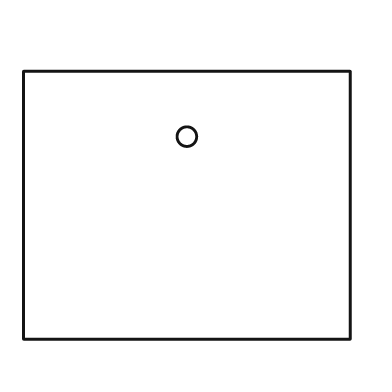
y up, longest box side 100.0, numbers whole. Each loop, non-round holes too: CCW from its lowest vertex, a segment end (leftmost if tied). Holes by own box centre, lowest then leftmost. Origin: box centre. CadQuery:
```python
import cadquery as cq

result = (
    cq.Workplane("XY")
    .moveTo(-50.0, -41.0)
    .lineTo(50.0, -41.0)
    .lineTo(50.0, 41.0)
    .lineTo(-50.0, 41.0)
    .close()
    .moveTo(0.0, 21.0)
    .circle(3.0)
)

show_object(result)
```